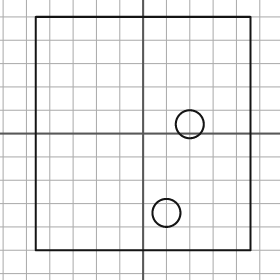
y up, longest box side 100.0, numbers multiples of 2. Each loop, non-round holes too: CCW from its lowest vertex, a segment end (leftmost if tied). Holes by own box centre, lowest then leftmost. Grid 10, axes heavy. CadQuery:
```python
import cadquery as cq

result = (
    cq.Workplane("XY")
    .moveTo(-46.0, -50.0)
    .lineTo(46.0, -50.0)
    .lineTo(46.0, 50.0)
    .lineTo(-46.0, 50.0)
    .close()
    .moveTo(10.0, -34.0)
    .circle(6.0)
    .moveTo(20.0, 4.0)
    .circle(6.0)
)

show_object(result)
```